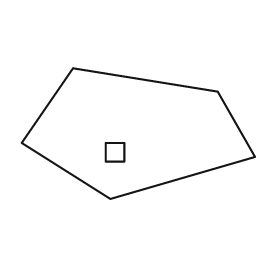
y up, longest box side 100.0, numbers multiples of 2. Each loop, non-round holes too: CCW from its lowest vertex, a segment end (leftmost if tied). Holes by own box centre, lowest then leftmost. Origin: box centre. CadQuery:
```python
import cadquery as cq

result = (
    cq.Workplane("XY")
    .moveTo(-12.0, -28.0)
    .lineTo(50.0, -10.0)
    .lineTo(34.0, 18.0)
    .lineTo(-28.0, 28.0)
    .lineTo(-50.0, -4.0)
    .close()
    .moveTo(-14.0, -12.0)
    .lineTo(-6.0, -12.0)
    .lineTo(-6.0, -4.0)
    .lineTo(-14.0, -4.0)
    .close()
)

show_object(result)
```